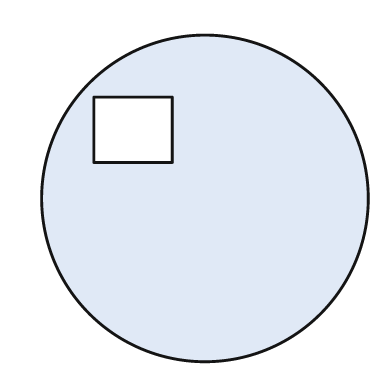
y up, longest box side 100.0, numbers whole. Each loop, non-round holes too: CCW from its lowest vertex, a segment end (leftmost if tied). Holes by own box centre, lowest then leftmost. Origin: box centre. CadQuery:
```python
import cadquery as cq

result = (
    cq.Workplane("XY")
    .moveTo(0.0, 0.0)
    .circle(50.0)
    .moveTo(-34.0, 11.0)
    .lineTo(-10.0, 11.0)
    .lineTo(-10.0, 31.0)
    .lineTo(-34.0, 31.0)
    .close()
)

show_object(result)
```